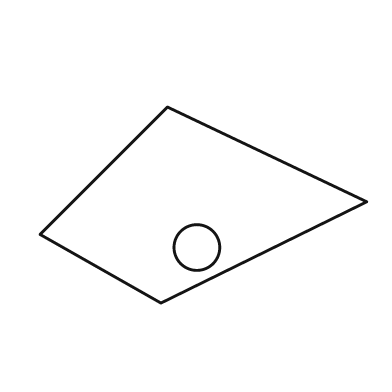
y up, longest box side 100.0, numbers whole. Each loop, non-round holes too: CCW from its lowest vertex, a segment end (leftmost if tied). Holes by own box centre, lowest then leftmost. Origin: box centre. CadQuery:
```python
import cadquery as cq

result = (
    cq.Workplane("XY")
    .moveTo(-13.0, -30.0)
    .lineTo(50.0, 1.0)
    .lineTo(-11.0, 30.0)
    .lineTo(-50.0, -9.0)
    .close()
    .moveTo(-2.0, -13.0)
    .circle(7.0)
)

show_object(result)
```